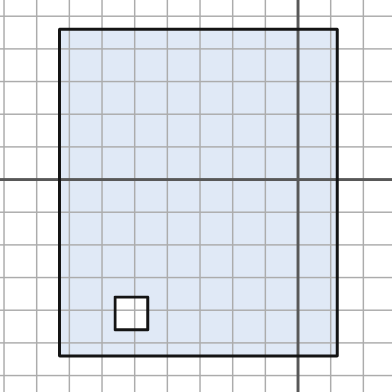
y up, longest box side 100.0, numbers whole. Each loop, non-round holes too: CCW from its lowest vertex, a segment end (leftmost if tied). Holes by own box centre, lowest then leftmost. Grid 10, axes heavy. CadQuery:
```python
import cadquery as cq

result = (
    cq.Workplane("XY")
    .moveTo(-73.0, -54.0)
    .lineTo(12.0, -54.0)
    .lineTo(12.0, 46.0)
    .lineTo(-73.0, 46.0)
    .close()
    .moveTo(-56.0, -46.0)
    .lineTo(-46.0, -46.0)
    .lineTo(-46.0, -36.0)
    .lineTo(-56.0, -36.0)
    .close()
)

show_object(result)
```